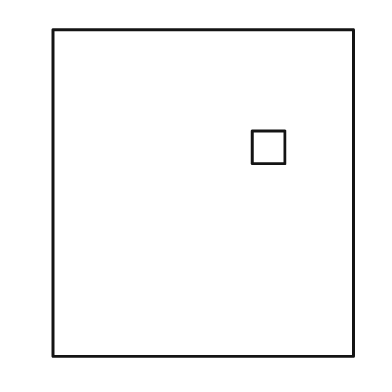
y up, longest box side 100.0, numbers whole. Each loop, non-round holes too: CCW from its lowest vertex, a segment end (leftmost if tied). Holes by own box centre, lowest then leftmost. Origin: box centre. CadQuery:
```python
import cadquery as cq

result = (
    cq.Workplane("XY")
    .moveTo(-46.0, -50.0)
    .lineTo(46.0, -50.0)
    .lineTo(46.0, 50.0)
    .lineTo(-46.0, 50.0)
    .close()
    .moveTo(15.0, 9.0)
    .lineTo(25.0, 9.0)
    .lineTo(25.0, 19.0)
    .lineTo(15.0, 19.0)
    .close()
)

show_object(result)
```